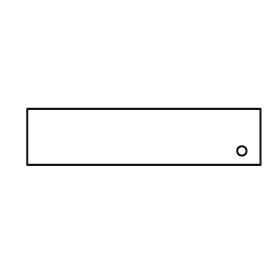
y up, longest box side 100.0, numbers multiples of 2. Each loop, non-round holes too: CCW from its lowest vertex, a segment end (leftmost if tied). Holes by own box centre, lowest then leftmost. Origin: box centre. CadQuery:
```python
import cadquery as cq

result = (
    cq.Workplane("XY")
    .moveTo(-50.0, -12.0)
    .lineTo(50.0, -12.0)
    .lineTo(50.0, 12.0)
    .lineTo(-50.0, 12.0)
    .close()
    .moveTo(42.0, -6.0)
    .circle(2.0)
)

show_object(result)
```